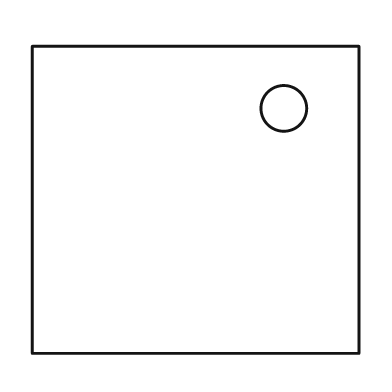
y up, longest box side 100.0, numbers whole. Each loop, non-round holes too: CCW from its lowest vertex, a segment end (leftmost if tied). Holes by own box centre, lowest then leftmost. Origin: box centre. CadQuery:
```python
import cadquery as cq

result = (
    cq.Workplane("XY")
    .moveTo(-50.0, -47.0)
    .lineTo(50.0, -47.0)
    .lineTo(50.0, 47.0)
    .lineTo(-50.0, 47.0)
    .close()
    .moveTo(27.0, 28.0)
    .circle(7.0)
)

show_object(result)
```